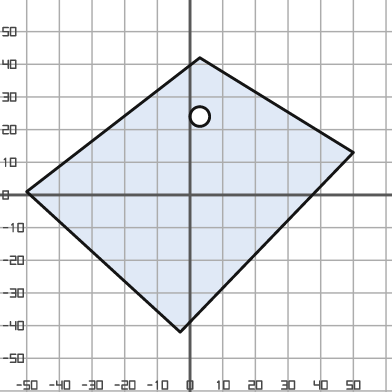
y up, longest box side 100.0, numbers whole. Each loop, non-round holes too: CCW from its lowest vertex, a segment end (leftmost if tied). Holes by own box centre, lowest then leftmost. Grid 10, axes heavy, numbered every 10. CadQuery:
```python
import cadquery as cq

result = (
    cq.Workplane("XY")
    .moveTo(-3.0, -42.0)
    .lineTo(50.0, 13.0)
    .lineTo(3.0, 42.0)
    .lineTo(-50.0, 1.0)
    .close()
    .moveTo(3.0, 24.0)
    .circle(3.0)
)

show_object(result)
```